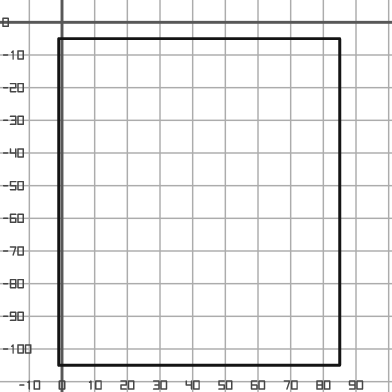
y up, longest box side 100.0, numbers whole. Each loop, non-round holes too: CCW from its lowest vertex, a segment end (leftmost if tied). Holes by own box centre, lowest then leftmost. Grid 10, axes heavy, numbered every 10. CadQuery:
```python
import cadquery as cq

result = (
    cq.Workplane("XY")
    .moveTo(-1.0, -105.0)
    .lineTo(85.0, -105.0)
    .lineTo(85.0, -5.0)
    .lineTo(-1.0, -5.0)
    .close()
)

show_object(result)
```